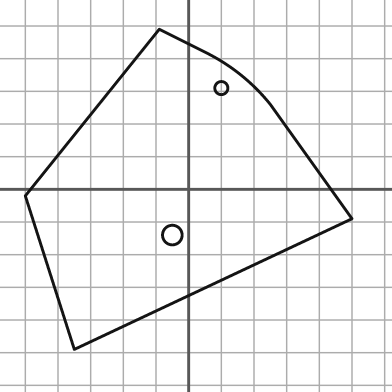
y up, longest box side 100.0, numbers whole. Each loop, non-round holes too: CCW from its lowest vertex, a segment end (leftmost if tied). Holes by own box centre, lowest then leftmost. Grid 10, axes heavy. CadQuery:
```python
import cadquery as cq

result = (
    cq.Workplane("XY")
    .moveTo(-35.0, -49.0)
    .lineTo(50.0, -9.0)
    .lineTo(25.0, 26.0)
    .threePointArc((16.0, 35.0), (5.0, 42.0))
    .lineTo(-9.0, 49.0)
    .lineTo(-50.0, -2.0)
    .close()
    .moveTo(-5.0, -14.0)
    .circle(3.0)
    .moveTo(10.0, 31.0)
    .circle(2.0)
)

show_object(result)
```